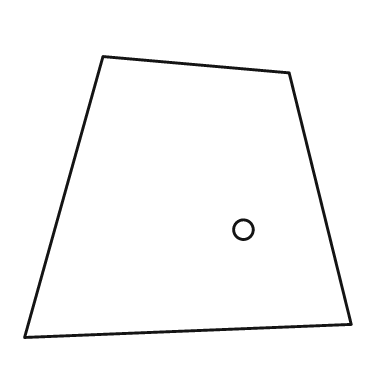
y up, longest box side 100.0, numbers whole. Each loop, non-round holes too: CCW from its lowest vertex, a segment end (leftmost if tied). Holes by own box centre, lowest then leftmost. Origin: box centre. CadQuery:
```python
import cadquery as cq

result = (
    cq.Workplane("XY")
    .moveTo(-50.0, -43.0)
    .lineTo(50.0, -39.0)
    .lineTo(31.0, 38.0)
    .lineTo(-26.0, 43.0)
    .close()
    .moveTo(17.0, -10.0)
    .circle(3.0)
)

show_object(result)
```